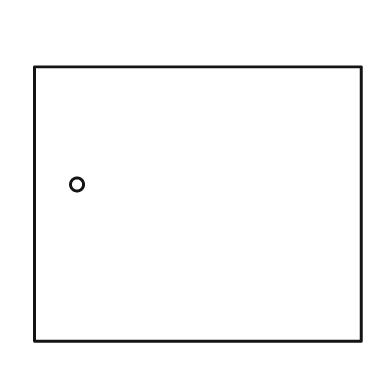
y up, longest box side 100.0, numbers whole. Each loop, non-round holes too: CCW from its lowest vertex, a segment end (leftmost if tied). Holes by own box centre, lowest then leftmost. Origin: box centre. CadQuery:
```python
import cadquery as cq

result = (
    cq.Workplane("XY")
    .moveTo(-50.0, -42.0)
    .lineTo(50.0, -42.0)
    .lineTo(50.0, 42.0)
    .lineTo(-50.0, 42.0)
    .close()
    .moveTo(-37.0, 6.0)
    .circle(2.0)
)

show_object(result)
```